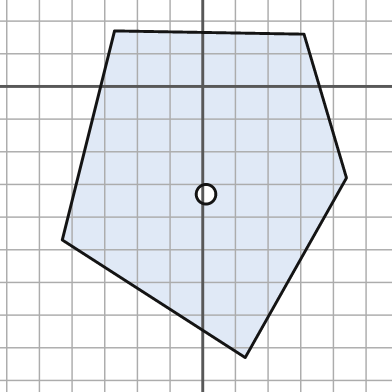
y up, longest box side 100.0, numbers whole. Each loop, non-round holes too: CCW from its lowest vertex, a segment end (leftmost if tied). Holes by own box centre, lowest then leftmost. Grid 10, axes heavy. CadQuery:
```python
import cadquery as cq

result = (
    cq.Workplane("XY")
    .moveTo(13.0, -83.0)
    .lineTo(44.0, -28.0)
    .lineTo(31.0, 16.0)
    .lineTo(-27.0, 17.0)
    .lineTo(-43.0, -47.0)
    .close()
    .moveTo(1.0, -33.0)
    .circle(3.0)
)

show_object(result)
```